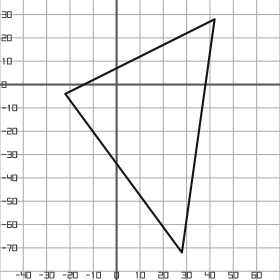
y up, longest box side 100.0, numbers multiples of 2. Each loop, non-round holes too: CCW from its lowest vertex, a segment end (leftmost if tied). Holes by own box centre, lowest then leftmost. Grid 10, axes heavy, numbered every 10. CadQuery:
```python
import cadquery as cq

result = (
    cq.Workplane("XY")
    .moveTo(28.0, -72.0)
    .lineTo(42.0, 28.0)
    .lineTo(-22.0, -4.0)
    .close()
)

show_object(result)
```